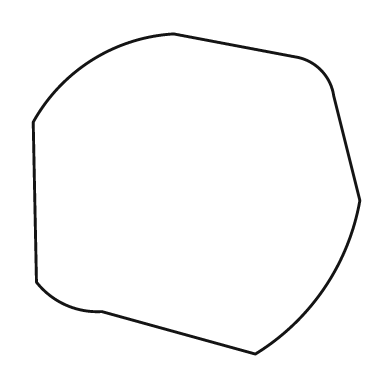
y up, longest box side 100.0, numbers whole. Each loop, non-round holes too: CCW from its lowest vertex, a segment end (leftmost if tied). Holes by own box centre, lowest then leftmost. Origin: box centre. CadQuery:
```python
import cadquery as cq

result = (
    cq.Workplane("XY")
    .moveTo(18.0, -49.0)
    .threePointArc((39.0, -29.0), (50.0, -2.0))
    .lineTo(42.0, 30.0)
    .threePointArc((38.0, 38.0), (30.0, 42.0))
    .lineTo(-7.0, 49.0)
    .threePointArc((-32.0, 41.0), (-50.0, 22.0))
    .lineTo(-49.0, -27.0)
    .threePointArc((-40.0, -34.0), (-29.0, -36.0))
    .close()
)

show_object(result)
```